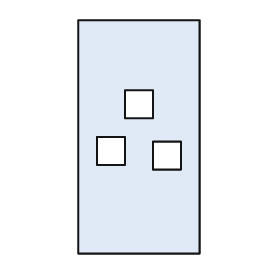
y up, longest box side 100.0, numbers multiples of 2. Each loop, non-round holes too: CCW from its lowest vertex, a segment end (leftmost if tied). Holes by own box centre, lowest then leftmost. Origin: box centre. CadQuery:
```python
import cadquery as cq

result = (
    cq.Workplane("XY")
    .moveTo(-26.0, -50.0)
    .lineTo(26.0, -50.0)
    .lineTo(26.0, 50.0)
    .lineTo(-26.0, 50.0)
    .close()
    .moveTo(6.0, -14.0)
    .lineTo(18.0, -14.0)
    .lineTo(18.0, -2.0)
    .lineTo(6.0, -2.0)
    .close()
    .moveTo(-18.0, -12.0)
    .lineTo(-6.0, -12.0)
    .lineTo(-6.0, 0.0)
    .lineTo(-18.0, 0.0)
    .close()
    .moveTo(-6.0, 8.0)
    .lineTo(6.0, 8.0)
    .lineTo(6.0, 20.0)
    .lineTo(-6.0, 20.0)
    .close()
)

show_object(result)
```